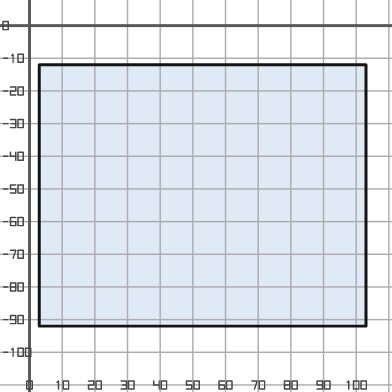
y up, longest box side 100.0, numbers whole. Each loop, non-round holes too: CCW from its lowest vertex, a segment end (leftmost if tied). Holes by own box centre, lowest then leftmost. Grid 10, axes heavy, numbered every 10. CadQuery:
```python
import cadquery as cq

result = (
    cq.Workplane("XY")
    .moveTo(3.0, -92.0)
    .lineTo(103.0, -92.0)
    .lineTo(103.0, -12.0)
    .lineTo(3.0, -12.0)
    .close()
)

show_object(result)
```